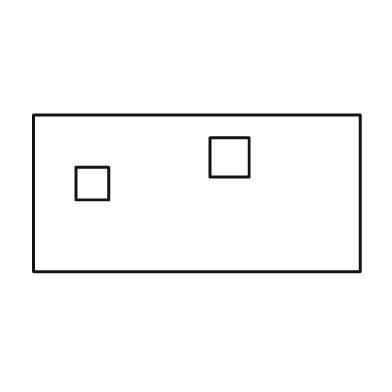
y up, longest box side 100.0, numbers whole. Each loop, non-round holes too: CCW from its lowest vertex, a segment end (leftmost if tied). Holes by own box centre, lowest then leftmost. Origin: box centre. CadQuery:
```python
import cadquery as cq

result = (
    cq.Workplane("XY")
    .moveTo(-50.0, -24.0)
    .lineTo(50.0, -24.0)
    .lineTo(50.0, 24.0)
    .lineTo(-50.0, 24.0)
    .close()
    .moveTo(-37.0, -2.0)
    .lineTo(-27.0, -2.0)
    .lineTo(-27.0, 8.0)
    .lineTo(-37.0, 8.0)
    .close()
    .moveTo(4.0, 5.0)
    .lineTo(16.0, 5.0)
    .lineTo(16.0, 17.0)
    .lineTo(4.0, 17.0)
    .close()
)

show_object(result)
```